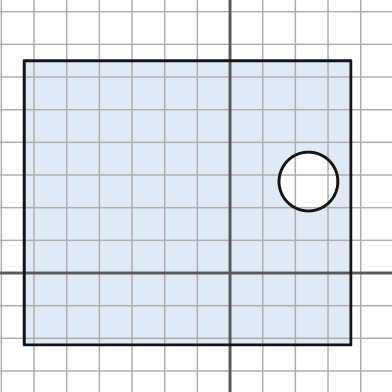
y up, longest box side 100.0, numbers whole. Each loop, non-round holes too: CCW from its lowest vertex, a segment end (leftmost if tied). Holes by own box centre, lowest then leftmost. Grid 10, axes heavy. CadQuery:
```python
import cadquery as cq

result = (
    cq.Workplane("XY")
    .moveTo(-63.0, -22.0)
    .lineTo(37.0, -22.0)
    .lineTo(37.0, 65.0)
    .lineTo(-63.0, 65.0)
    .close()
    .moveTo(24.0, 28.0)
    .circle(9.0)
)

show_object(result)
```